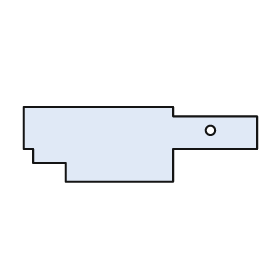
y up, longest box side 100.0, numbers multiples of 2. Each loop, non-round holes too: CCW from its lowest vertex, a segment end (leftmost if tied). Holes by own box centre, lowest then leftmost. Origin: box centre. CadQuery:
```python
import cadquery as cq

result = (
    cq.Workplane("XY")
    .moveTo(-32.0, -16.0)
    .lineTo(14.0, -16.0)
    .lineTo(14.0, -2.0)
    .lineTo(50.0, -2.0)
    .lineTo(50.0, 12.0)
    .lineTo(14.0, 12.0)
    .lineTo(14.0, 16.0)
    .lineTo(-50.0, 16.0)
    .lineTo(-50.0, -2.0)
    .lineTo(-46.0, -2.0)
    .lineTo(-46.0, -8.0)
    .lineTo(-32.0, -8.0)
    .close()
    .moveTo(30.0, 6.0)
    .circle(2.0)
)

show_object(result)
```